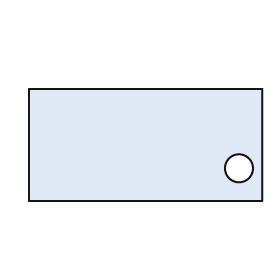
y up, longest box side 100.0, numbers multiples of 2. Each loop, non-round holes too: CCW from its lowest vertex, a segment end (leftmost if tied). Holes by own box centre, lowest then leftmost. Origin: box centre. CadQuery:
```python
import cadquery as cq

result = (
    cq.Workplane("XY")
    .moveTo(-50.0, -24.0)
    .lineTo(50.0, -24.0)
    .lineTo(50.0, 24.0)
    .lineTo(-50.0, 24.0)
    .close()
    .moveTo(40.0, -10.0)
    .circle(6.0)
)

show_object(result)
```